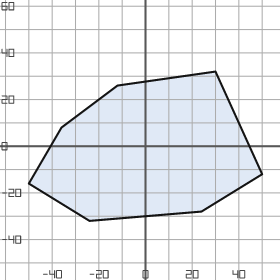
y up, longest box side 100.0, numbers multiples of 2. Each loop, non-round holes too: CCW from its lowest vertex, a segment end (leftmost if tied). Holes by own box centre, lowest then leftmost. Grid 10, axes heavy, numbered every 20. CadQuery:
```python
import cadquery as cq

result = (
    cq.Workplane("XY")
    .moveTo(-24.0, -32.0)
    .lineTo(24.0, -28.0)
    .lineTo(50.0, -12.0)
    .lineTo(30.0, 32.0)
    .lineTo(-12.0, 26.0)
    .lineTo(-36.0, 8.0)
    .lineTo(-50.0, -16.0)
    .close()
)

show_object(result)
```